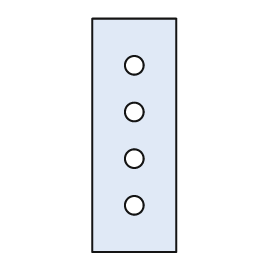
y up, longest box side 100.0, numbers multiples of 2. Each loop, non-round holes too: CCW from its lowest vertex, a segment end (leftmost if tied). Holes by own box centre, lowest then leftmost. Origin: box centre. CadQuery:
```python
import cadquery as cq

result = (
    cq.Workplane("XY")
    .moveTo(-18.0, -50.0)
    .lineTo(18.0, -50.0)
    .lineTo(18.0, 50.0)
    .lineTo(-18.0, 50.0)
    .close()
    .moveTo(0.0, -30.0)
    .circle(4.0)
    .moveTo(0.0, -10.0)
    .circle(4.0)
    .moveTo(0.0, 10.0)
    .circle(4.0)
    .moveTo(0.0, 30.0)
    .circle(4.0)
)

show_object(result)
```